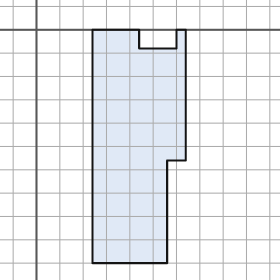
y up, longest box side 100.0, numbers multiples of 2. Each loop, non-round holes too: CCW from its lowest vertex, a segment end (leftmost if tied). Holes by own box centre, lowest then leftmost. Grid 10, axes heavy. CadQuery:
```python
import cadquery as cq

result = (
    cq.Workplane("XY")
    .moveTo(24.0, -100.0)
    .lineTo(56.0, -100.0)
    .lineTo(56.0, -56.0)
    .lineTo(64.0, -56.0)
    .lineTo(64.0, 0.0)
    .lineTo(60.0, 0.0)
    .lineTo(60.0, -8.0)
    .lineTo(44.0, -8.0)
    .lineTo(44.0, 0.0)
    .lineTo(24.0, 0.0)
    .close()
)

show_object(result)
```